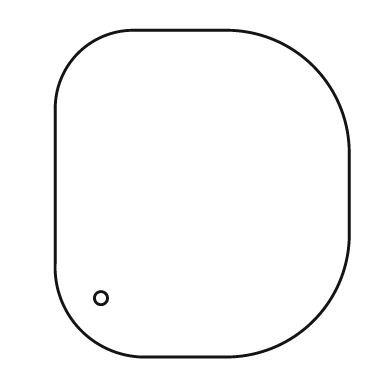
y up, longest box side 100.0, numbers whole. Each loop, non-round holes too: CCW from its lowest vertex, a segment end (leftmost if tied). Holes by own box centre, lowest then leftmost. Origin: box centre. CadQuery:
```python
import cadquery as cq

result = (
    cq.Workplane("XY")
    .moveTo(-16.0, -50.0)
    .lineTo(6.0, -50.0)
    .threePointArc((34.0, -39.0), (45.0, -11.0))
    .lineTo(45.0, 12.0)
    .threePointArc((34.0, 39.0), (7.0, 50.0))
    .lineTo(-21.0, 50.0)
    .threePointArc((-38.0, 43.0), (-45.0, 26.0))
    .lineTo(-45.0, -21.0)
    .threePointArc((-37.0, -42.0), (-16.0, -50.0))
    .close()
    .moveTo(-31.0, -32.0)
    .circle(2.0)
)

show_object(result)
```